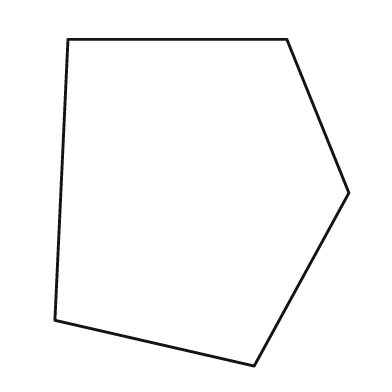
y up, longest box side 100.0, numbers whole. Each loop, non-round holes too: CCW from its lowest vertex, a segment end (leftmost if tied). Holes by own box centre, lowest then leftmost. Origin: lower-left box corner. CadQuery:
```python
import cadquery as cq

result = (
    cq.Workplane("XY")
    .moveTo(61.0, 0.0)
    .lineTo(90.0, 53.0)
    .lineTo(71.0, 100.0)
    .lineTo(4.0, 100.0)
    .lineTo(0.0, 14.0)
    .close()
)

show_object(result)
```